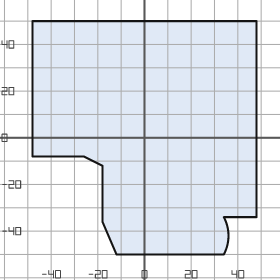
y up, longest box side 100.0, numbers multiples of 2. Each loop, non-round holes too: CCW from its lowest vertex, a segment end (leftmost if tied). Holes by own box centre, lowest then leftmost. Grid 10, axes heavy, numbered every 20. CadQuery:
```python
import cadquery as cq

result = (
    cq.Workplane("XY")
    .moveTo(-12.0, -50.0)
    .lineTo(34.0, -50.0)
    .threePointArc((36.0, -42.0), (34.0, -34.0))
    .lineTo(48.0, -34.0)
    .lineTo(48.0, 50.0)
    .lineTo(-48.0, 50.0)
    .lineTo(-48.0, -8.0)
    .lineTo(-26.0, -8.0)
    .lineTo(-18.0, -12.0)
    .lineTo(-18.0, -36.0)
    .close()
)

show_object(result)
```